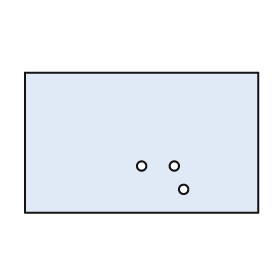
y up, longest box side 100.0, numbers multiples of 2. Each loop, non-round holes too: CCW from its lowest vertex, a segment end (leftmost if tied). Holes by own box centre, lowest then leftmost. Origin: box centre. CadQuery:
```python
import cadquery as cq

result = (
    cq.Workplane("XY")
    .moveTo(-50.0, -30.0)
    .lineTo(50.0, -30.0)
    .lineTo(50.0, 30.0)
    .lineTo(-50.0, 30.0)
    .close()
    .moveTo(18.0, -20.0)
    .circle(2.0)
    .moveTo(0.0, -10.0)
    .circle(2.0)
    .moveTo(14.0, -10.0)
    .circle(2.0)
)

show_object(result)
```